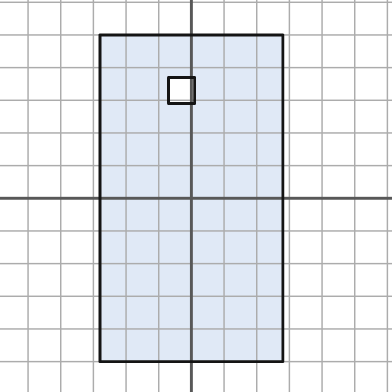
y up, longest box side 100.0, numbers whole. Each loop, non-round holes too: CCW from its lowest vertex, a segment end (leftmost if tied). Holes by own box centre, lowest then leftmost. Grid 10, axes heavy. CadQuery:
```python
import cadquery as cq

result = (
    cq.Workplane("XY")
    .moveTo(-28.0, -50.0)
    .lineTo(28.0, -50.0)
    .lineTo(28.0, 50.0)
    .lineTo(-28.0, 50.0)
    .close()
    .moveTo(-7.0, 29.0)
    .lineTo(1.0, 29.0)
    .lineTo(1.0, 37.0)
    .lineTo(-7.0, 37.0)
    .close()
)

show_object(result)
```